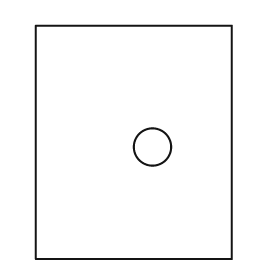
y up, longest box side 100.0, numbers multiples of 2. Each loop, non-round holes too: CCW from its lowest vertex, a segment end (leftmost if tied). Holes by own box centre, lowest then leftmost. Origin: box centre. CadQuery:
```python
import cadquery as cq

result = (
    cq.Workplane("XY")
    .moveTo(-42.0, -50.0)
    .lineTo(42.0, -50.0)
    .lineTo(42.0, 50.0)
    .lineTo(-42.0, 50.0)
    .close()
    .moveTo(8.0, -2.0)
    .circle(8.0)
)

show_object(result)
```